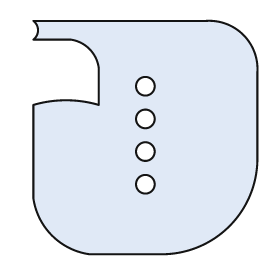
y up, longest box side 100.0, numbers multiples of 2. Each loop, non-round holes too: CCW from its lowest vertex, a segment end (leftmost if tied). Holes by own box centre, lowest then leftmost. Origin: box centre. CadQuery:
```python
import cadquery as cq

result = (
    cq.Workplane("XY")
    .moveTo(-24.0, -50.0)
    .lineTo(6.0, -50.0)
    .threePointArc((36.0, -38.0), (48.0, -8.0))
    .lineTo(48.0, 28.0)
    .threePointArc((42.0, 44.0), (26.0, 50.0))
    .lineTo(-48.0, 50.0)
    .threePointArc((-46.0, 46.0), (-48.0, 42.0))
    .lineTo(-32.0, 42.0)
    .threePointArc((-24.0, 38.0), (-20.0, 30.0))
    .lineTo(-20.0, 14.0)
    .threePointArc((-34.0, 16.0), (-48.0, 14.0))
    .lineTo(-48.0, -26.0)
    .threePointArc((-40.0, -42.0), (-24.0, -50.0))
    .close()
    .moveTo(0.0, -20.0)
    .circle(4.0)
    .moveTo(0.0, -6.0)
    .circle(4.0)
    .moveTo(0.0, 8.0)
    .circle(4.0)
    .moveTo(0.0, 22.0)
    .circle(4.0)
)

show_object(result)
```